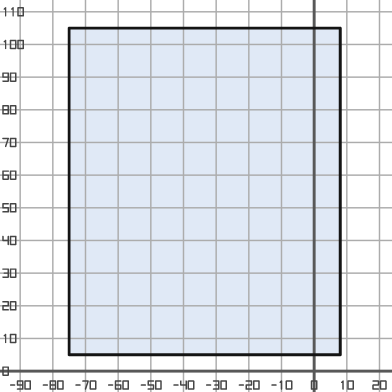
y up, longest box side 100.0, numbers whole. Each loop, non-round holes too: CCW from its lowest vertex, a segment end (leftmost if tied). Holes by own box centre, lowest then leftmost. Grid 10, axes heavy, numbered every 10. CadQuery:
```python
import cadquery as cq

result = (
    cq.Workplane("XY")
    .moveTo(-75.0, 5.0)
    .lineTo(8.0, 5.0)
    .lineTo(8.0, 105.0)
    .lineTo(-75.0, 105.0)
    .close()
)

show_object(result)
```